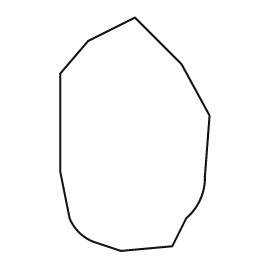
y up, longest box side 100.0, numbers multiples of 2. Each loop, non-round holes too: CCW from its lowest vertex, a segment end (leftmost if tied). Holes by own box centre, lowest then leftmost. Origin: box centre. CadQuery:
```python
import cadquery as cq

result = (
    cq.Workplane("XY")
    .moveTo(-6.0, -50.0)
    .lineTo(16.0, -48.0)
    .lineTo(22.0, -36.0)
    .threePointArc((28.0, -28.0), (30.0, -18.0))
    .lineTo(32.0, 8.0)
    .lineTo(20.0, 30.0)
    .lineTo(0.0, 50.0)
    .lineTo(-20.0, 40.0)
    .lineTo(-32.0, 26.0)
    .lineTo(-32.0, -16.0)
    .lineTo(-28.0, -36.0)
    .threePointArc((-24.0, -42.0), (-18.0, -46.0))
    .close()
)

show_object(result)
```